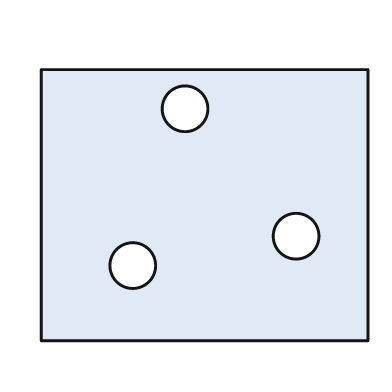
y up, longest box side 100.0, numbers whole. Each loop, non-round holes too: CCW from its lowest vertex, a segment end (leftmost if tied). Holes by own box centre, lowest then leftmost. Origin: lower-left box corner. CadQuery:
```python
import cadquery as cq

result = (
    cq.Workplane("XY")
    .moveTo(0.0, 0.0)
    .lineTo(100.0, 0.0)
    .lineTo(100.0, 83.0)
    .lineTo(0.0, 83.0)
    .close()
    .moveTo(28.0, 23.0)
    .circle(7.0)
    .moveTo(78.0, 32.0)
    .circle(7.0)
    .moveTo(44.0, 71.0)
    .circle(7.0)
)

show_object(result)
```